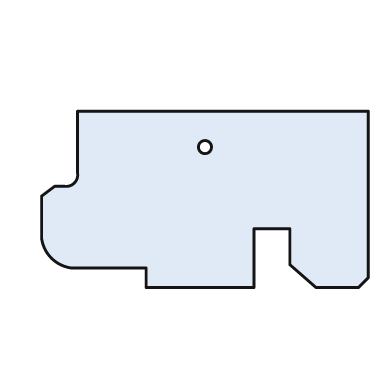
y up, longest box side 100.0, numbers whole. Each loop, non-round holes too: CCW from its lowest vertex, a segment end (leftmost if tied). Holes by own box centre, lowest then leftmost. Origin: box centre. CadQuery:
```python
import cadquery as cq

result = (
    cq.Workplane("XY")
    .moveTo(-18.0, -27.0)
    .lineTo(15.0, -27.0)
    .lineTo(15.0, -9.0)
    .lineTo(26.0, -9.0)
    .lineTo(26.0, -20.0)
    .lineTo(34.0, -27.0)
    .lineTo(47.0, -27.0)
    .lineTo(50.0, -24.0)
    .lineTo(50.0, 27.0)
    .lineTo(-39.0, 27.0)
    .lineTo(-39.0, 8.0)
    .threePointArc((-40.0, 5.0), (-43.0, 4.0))
    .lineTo(-46.0, 4.0)
    .lineTo(-50.0, 1.0)
    .lineTo(-50.0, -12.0)
    .threePointArc((-47.0, -18.0), (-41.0, -21.0))
    .lineTo(-18.0, -21.0)
    .close()
    .moveTo(0.0, 16.0)
    .circle(2.0)
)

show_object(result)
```